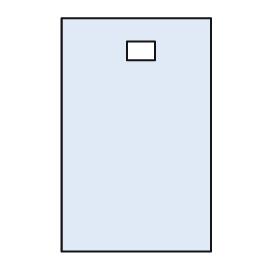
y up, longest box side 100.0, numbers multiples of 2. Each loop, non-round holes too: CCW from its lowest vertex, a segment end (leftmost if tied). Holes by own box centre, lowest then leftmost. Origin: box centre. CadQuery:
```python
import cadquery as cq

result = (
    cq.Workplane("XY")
    .moveTo(-32.0, -50.0)
    .lineTo(32.0, -50.0)
    .lineTo(32.0, 50.0)
    .lineTo(-32.0, 50.0)
    .close()
    .moveTo(-4.0, 32.0)
    .lineTo(8.0, 32.0)
    .lineTo(8.0, 40.0)
    .lineTo(-4.0, 40.0)
    .close()
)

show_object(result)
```